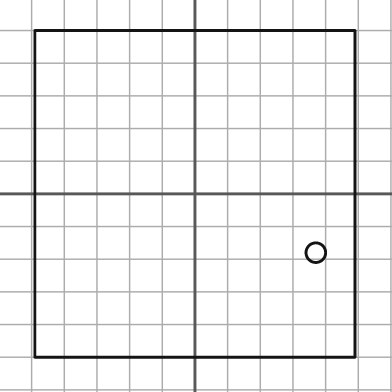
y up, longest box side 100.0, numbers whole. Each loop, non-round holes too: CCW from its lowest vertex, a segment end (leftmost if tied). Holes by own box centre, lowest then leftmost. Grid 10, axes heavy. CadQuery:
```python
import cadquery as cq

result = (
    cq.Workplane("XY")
    .moveTo(-49.0, -50.0)
    .lineTo(49.0, -50.0)
    .lineTo(49.0, 50.0)
    .lineTo(-49.0, 50.0)
    .close()
    .moveTo(37.0, -18.0)
    .circle(3.0)
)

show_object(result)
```